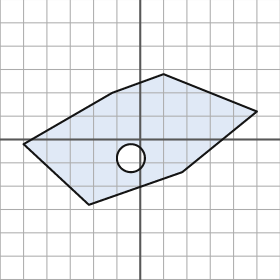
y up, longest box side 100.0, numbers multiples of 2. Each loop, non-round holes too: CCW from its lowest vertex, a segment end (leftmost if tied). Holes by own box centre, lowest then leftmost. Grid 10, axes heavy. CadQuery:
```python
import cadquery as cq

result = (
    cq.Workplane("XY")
    .moveTo(-22.0, -28.0)
    .lineTo(18.0, -14.0)
    .lineTo(50.0, 12.0)
    .lineTo(10.0, 28.0)
    .lineTo(-12.0, 20.0)
    .lineTo(-50.0, -2.0)
    .close()
    .moveTo(-4.0, -8.0)
    .circle(6.0)
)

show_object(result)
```